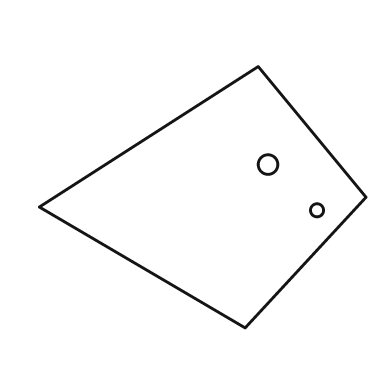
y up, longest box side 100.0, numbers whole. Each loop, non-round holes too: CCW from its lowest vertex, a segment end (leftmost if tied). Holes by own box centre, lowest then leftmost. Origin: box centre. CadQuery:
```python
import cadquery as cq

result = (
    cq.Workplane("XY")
    .moveTo(13.0, -40.0)
    .lineTo(50.0, 0.0)
    .lineTo(17.0, 40.0)
    .lineTo(-50.0, -3.0)
    .close()
    .moveTo(35.0, -4.0)
    .circle(2.0)
    .moveTo(20.0, 10.0)
    .circle(3.0)
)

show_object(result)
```